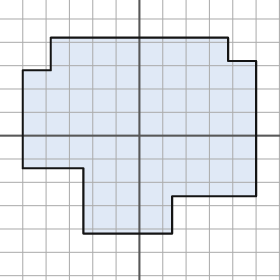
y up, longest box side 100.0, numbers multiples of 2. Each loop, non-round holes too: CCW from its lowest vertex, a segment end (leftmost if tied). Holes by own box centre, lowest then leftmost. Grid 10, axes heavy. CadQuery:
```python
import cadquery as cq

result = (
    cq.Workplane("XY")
    .moveTo(-24.0, -42.0)
    .lineTo(14.0, -42.0)
    .lineTo(14.0, -26.0)
    .lineTo(50.0, -26.0)
    .lineTo(50.0, 32.0)
    .lineTo(38.0, 32.0)
    .lineTo(38.0, 42.0)
    .lineTo(-38.0, 42.0)
    .lineTo(-38.0, 28.0)
    .lineTo(-50.0, 28.0)
    .lineTo(-50.0, -14.0)
    .lineTo(-24.0, -14.0)
    .close()
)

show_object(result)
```